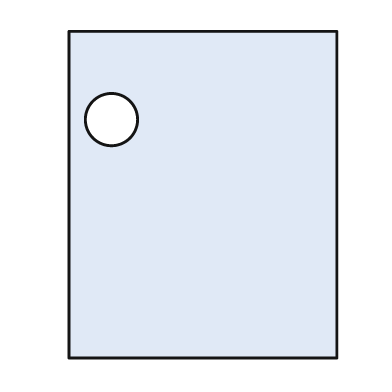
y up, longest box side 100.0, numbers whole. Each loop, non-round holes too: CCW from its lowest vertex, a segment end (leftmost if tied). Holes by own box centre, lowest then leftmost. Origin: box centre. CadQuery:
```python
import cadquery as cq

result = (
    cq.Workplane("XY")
    .moveTo(-41.0, -50.0)
    .lineTo(41.0, -50.0)
    .lineTo(41.0, 50.0)
    .lineTo(-41.0, 50.0)
    .close()
    .moveTo(-28.0, 23.0)
    .circle(8.0)
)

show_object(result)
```